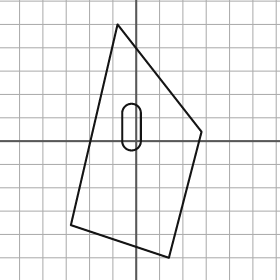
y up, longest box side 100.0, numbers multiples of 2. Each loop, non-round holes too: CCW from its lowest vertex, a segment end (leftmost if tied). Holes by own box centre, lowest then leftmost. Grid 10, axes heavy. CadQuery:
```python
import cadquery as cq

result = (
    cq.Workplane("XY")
    .moveTo(14.0, -50.0)
    .lineTo(28.0, 4.0)
    .lineTo(-8.0, 50.0)
    .lineTo(-28.0, -36.0)
    .close()
    .moveTo(-6.0, 0.0)
    .threePointArc((-2.0, -4.0), (2.0, 0.0))
    .lineTo(2.0, 12.0)
    .threePointArc((-2.0, 16.0), (-6.0, 12.0))
    .close()
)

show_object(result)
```